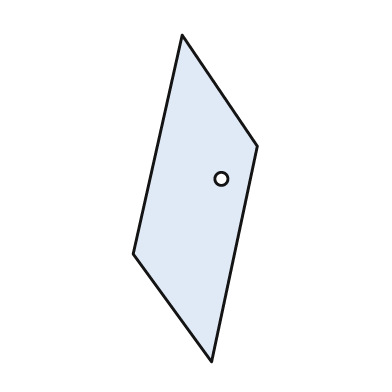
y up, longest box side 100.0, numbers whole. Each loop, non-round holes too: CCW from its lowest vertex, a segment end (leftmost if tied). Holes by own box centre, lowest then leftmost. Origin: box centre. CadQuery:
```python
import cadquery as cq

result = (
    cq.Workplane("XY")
    .moveTo(5.0, -50.0)
    .lineTo(19.0, 16.0)
    .lineTo(-4.0, 50.0)
    .lineTo(-19.0, -17.0)
    .close()
    .moveTo(8.0, 6.0)
    .circle(2.0)
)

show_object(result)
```